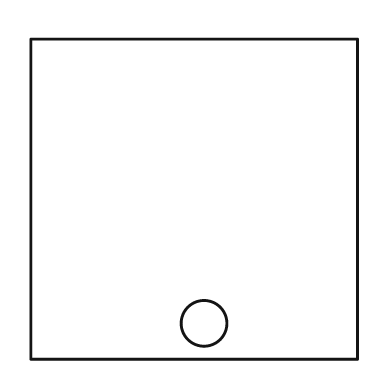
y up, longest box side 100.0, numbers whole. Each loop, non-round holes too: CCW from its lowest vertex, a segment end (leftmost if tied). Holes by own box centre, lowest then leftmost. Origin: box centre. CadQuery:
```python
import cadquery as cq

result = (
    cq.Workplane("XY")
    .moveTo(-50.0, -49.0)
    .lineTo(50.0, -49.0)
    .lineTo(50.0, 49.0)
    .lineTo(-50.0, 49.0)
    .close()
    .moveTo(3.0, -38.0)
    .circle(7.0)
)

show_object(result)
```